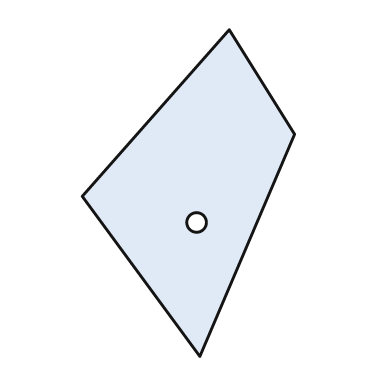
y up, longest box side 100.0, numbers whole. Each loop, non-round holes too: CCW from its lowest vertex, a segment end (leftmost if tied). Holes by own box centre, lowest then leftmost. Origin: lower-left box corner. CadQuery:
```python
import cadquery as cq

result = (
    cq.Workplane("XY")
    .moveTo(36.0, 0.0)
    .lineTo(65.0, 68.0)
    .lineTo(45.0, 100.0)
    .lineTo(0.0, 49.0)
    .close()
    .moveTo(35.0, 41.0)
    .circle(3.0)
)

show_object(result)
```